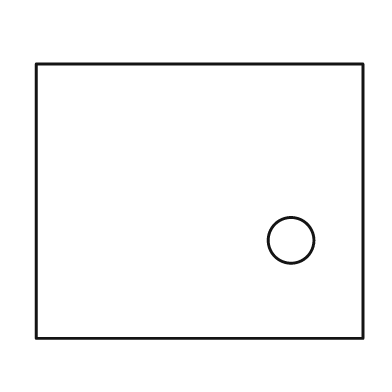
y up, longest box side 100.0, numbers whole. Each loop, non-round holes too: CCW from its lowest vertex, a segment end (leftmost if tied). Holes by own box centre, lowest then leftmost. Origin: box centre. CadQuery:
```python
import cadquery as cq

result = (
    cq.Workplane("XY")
    .moveTo(-50.0, -42.0)
    .lineTo(50.0, -42.0)
    .lineTo(50.0, 42.0)
    .lineTo(-50.0, 42.0)
    .close()
    .moveTo(28.0, -12.0)
    .circle(7.0)
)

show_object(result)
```